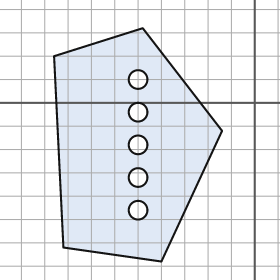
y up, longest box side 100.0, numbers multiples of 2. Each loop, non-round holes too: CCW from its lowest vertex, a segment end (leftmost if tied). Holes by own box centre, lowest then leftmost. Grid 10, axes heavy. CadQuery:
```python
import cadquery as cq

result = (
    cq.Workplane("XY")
    .moveTo(-40.0, -68.0)
    .lineTo(-14.0, -12.0)
    .lineTo(-48.0, 32.0)
    .lineTo(-86.0, 20.0)
    .lineTo(-82.0, -62.0)
    .close()
    .moveTo(-50.0, -46.0)
    .circle(4.0)
    .moveTo(-50.0, -32.0)
    .circle(4.0)
    .moveTo(-50.0, -18.0)
    .circle(4.0)
    .moveTo(-50.0, -4.0)
    .circle(4.0)
    .moveTo(-50.0, 10.0)
    .circle(4.0)
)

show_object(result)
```